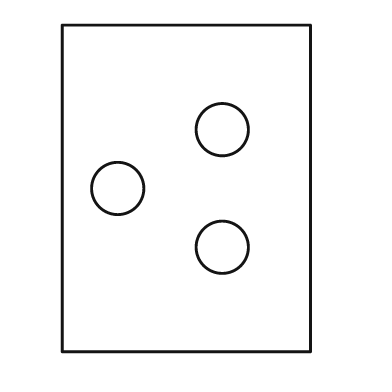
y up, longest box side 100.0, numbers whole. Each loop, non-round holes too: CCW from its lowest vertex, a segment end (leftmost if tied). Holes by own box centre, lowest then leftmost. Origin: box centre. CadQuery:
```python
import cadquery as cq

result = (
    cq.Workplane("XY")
    .moveTo(-38.0, -50.0)
    .lineTo(38.0, -50.0)
    .lineTo(38.0, 50.0)
    .lineTo(-38.0, 50.0)
    .close()
    .moveTo(11.0, -18.0)
    .circle(8.0)
    .moveTo(-21.0, 0.0)
    .circle(8.0)
    .moveTo(11.0, 18.0)
    .circle(8.0)
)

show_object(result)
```